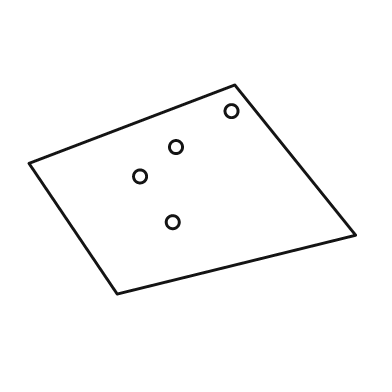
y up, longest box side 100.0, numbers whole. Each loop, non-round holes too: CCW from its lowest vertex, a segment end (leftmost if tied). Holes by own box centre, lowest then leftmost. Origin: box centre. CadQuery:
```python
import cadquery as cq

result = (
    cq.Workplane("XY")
    .moveTo(-23.0, -32.0)
    .lineTo(50.0, -14.0)
    .lineTo(13.0, 32.0)
    .lineTo(-50.0, 8.0)
    .close()
    .moveTo(-6.0, -10.0)
    .circle(2.0)
    .moveTo(-16.0, 4.0)
    .circle(2.0)
    .moveTo(-5.0, 13.0)
    .circle(2.0)
    .moveTo(12.0, 24.0)
    .circle(2.0)
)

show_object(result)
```